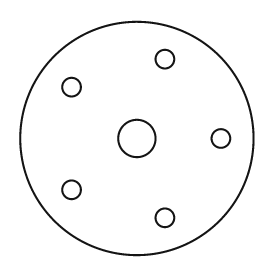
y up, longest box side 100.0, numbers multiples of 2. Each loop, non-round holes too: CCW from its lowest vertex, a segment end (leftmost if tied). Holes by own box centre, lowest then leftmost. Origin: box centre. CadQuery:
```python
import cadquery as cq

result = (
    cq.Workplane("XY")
    .moveTo(0.0, 0.0)
    .circle(50.0)
    .moveTo(12.0, -34.0)
    .circle(4.0)
    .moveTo(-28.0, -22.0)
    .circle(4.0)
    .moveTo(0.0, 0.0)
    .circle(8.0)
    .moveTo(36.0, 0.0)
    .circle(4.0)
    .moveTo(-28.0, 22.0)
    .circle(4.0)
    .moveTo(12.0, 34.0)
    .circle(4.0)
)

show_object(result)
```